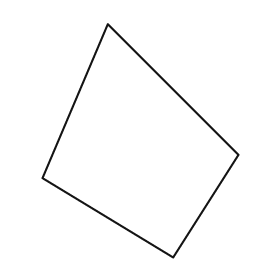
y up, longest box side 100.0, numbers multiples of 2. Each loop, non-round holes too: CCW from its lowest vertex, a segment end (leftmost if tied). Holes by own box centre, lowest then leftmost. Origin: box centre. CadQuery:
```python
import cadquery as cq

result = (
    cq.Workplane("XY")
    .moveTo(14.0, -50.0)
    .lineTo(42.0, -6.0)
    .lineTo(-14.0, 50.0)
    .lineTo(-42.0, -16.0)
    .close()
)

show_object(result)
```